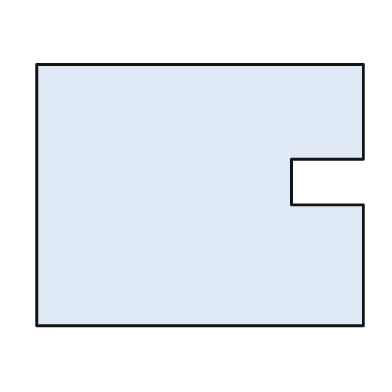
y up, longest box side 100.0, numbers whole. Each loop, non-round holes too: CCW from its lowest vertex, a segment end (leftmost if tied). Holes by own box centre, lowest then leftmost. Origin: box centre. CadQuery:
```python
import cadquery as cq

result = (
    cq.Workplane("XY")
    .moveTo(-50.0, -40.0)
    .lineTo(50.0, -40.0)
    .lineTo(50.0, -3.0)
    .lineTo(28.0, -3.0)
    .lineTo(28.0, 11.0)
    .lineTo(50.0, 11.0)
    .lineTo(50.0, 40.0)
    .lineTo(-50.0, 40.0)
    .close()
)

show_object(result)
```